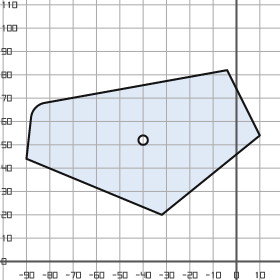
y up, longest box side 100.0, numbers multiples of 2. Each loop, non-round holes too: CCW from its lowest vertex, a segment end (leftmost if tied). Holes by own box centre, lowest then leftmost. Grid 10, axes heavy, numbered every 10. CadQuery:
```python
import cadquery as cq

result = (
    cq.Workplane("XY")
    .moveTo(-32.0, 20.0)
    .lineTo(10.0, 54.0)
    .lineTo(-4.0, 82.0)
    .lineTo(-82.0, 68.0)
    .threePointArc((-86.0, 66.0), (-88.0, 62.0))
    .lineTo(-90.0, 44.0)
    .close()
    .moveTo(-40.0, 52.0)
    .circle(2.0)
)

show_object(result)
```